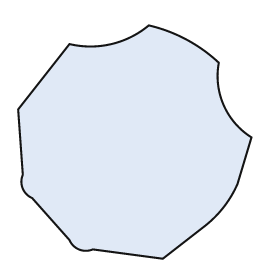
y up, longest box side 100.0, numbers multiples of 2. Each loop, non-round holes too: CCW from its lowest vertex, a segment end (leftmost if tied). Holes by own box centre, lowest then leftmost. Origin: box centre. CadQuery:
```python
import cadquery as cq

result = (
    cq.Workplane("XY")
    .moveTo(12.0, -50.0)
    .lineTo(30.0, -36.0)
    .threePointArc((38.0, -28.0), (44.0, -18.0))
    .lineTo(50.0, 2.0)
    .threePointArc((38.0, 16.0), (36.0, 34.0))
    .threePointArc((22.0, 44.0), (6.0, 50.0))
    .threePointArc((-10.0, 42.0), (-28.0, 42.0))
    .lineTo(-50.0, 14.0)
    .lineTo(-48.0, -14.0)
    .threePointArc((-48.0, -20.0), (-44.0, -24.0))
    .lineTo(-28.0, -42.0)
    .threePointArc((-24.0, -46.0), (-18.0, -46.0))
    .close()
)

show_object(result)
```